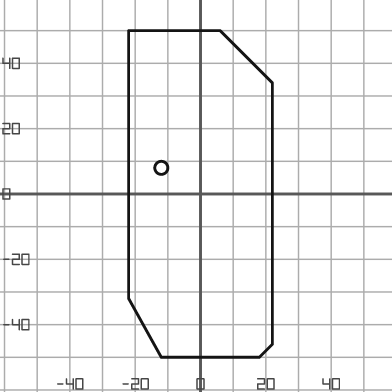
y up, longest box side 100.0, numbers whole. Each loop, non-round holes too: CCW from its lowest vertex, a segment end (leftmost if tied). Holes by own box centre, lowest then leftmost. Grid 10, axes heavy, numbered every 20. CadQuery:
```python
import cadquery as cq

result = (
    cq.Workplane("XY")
    .moveTo(-12.0, -50.0)
    .lineTo(18.0, -50.0)
    .lineTo(22.0, -46.0)
    .lineTo(22.0, 34.0)
    .lineTo(6.0, 50.0)
    .lineTo(-22.0, 50.0)
    .lineTo(-22.0, -32.0)
    .close()
    .moveTo(-12.0, 8.0)
    .circle(2.0)
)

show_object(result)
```